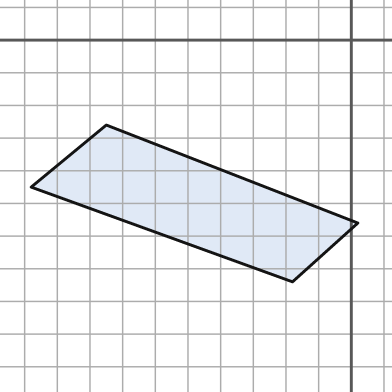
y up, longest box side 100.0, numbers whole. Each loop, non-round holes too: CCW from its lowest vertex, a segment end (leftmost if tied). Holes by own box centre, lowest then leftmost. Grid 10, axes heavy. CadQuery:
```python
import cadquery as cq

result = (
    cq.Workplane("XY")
    .moveTo(-18.0, -74.0)
    .lineTo(2.0, -56.0)
    .lineTo(-75.0, -26.0)
    .lineTo(-98.0, -45.0)
    .close()
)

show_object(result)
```